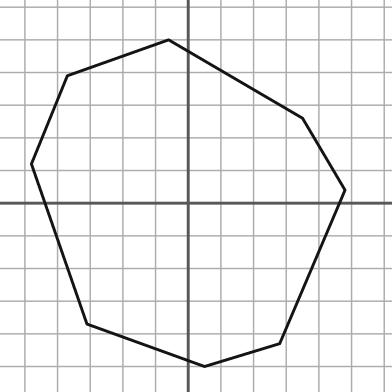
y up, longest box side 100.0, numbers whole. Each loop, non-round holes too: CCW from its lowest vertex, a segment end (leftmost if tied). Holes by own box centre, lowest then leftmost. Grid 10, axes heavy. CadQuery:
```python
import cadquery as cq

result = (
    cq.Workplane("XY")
    .moveTo(5.0, -50.0)
    .lineTo(28.0, -43.0)
    .lineTo(48.0, 4.0)
    .lineTo(35.0, 26.0)
    .lineTo(-6.0, 50.0)
    .lineTo(-37.0, 39.0)
    .lineTo(-48.0, 12.0)
    .lineTo(-31.0, -37.0)
    .close()
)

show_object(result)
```